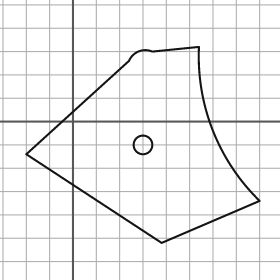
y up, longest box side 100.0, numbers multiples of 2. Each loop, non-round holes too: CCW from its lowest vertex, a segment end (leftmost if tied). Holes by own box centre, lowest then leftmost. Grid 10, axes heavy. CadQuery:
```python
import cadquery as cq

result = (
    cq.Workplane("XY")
    .moveTo(38.0, -52.0)
    .lineTo(80.0, -34.0)
    .threePointArc((60.0, -4.0), (54.0, 32.0))
    .lineTo(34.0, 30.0)
    .threePointArc((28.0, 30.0), (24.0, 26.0))
    .lineTo(-20.0, -14.0)
    .close()
    .moveTo(30.0, -10.0)
    .circle(4.0)
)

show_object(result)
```